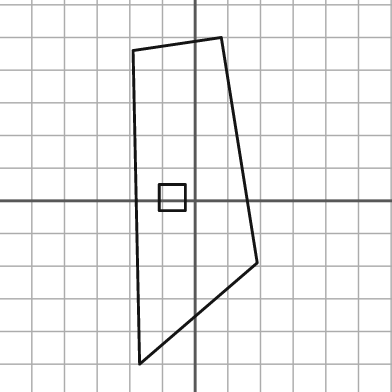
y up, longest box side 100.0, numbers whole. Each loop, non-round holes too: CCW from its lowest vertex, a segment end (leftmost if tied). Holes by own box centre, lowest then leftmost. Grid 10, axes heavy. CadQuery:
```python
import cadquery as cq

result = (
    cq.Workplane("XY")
    .moveTo(-17.0, -50.0)
    .lineTo(19.0, -19.0)
    .lineTo(8.0, 50.0)
    .lineTo(-19.0, 46.0)
    .close()
    .moveTo(-11.0, -3.0)
    .lineTo(-3.0, -3.0)
    .lineTo(-3.0, 5.0)
    .lineTo(-11.0, 5.0)
    .close()
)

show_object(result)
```